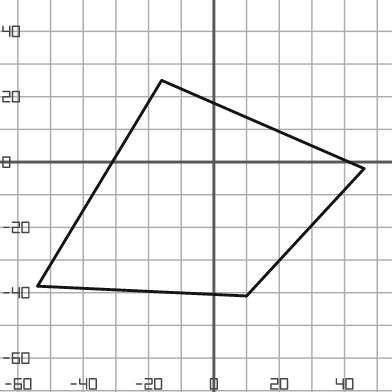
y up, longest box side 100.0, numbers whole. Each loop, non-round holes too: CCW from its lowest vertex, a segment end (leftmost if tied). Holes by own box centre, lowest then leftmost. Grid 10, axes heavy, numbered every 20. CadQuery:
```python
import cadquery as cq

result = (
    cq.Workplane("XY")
    .moveTo(10.0, -41.0)
    .lineTo(46.0, -2.0)
    .lineTo(-16.0, 25.0)
    .lineTo(-54.0, -38.0)
    .close()
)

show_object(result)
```